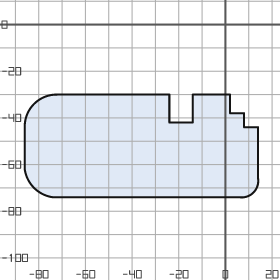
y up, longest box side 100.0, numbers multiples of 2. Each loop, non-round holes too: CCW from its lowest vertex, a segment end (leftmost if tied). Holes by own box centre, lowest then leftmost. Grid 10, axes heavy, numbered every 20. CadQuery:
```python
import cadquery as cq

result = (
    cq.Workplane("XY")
    .moveTo(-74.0, -74.0)
    .lineTo(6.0, -74.0)
    .threePointArc((12.0, -72.0), (14.0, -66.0))
    .lineTo(14.0, -44.0)
    .lineTo(8.0, -44.0)
    .lineTo(8.0, -38.0)
    .lineTo(2.0, -38.0)
    .lineTo(2.0, -30.0)
    .lineTo(-14.0, -30.0)
    .lineTo(-14.0, -42.0)
    .lineTo(-24.0, -42.0)
    .lineTo(-24.0, -30.0)
    .lineTo(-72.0, -30.0)
    .threePointArc((-82.0, -34.0), (-86.0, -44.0))
    .lineTo(-86.0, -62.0)
    .threePointArc((-82.0, -70.0), (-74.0, -74.0))
    .close()
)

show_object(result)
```